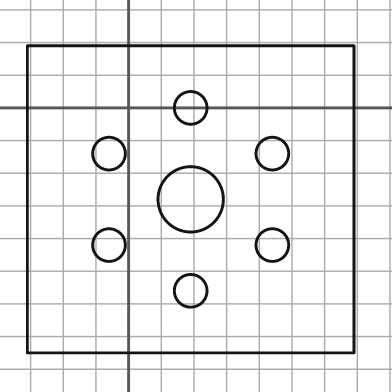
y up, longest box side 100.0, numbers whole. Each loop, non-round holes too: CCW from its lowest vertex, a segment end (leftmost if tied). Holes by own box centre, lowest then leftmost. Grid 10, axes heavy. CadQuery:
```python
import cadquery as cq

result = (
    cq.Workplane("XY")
    .moveTo(-31.0, -75.0)
    .lineTo(69.0, -75.0)
    .lineTo(69.0, 19.0)
    .lineTo(-31.0, 19.0)
    .close()
    .moveTo(19.0, -56.0)
    .circle(5.0)
    .moveTo(-6.0, -42.0)
    .circle(5.0)
    .moveTo(44.0, -42.0)
    .circle(5.0)
    .moveTo(19.0, -28.0)
    .circle(10.0)
    .moveTo(-6.0, -14.0)
    .circle(5.0)
    .moveTo(44.0, -14.0)
    .circle(5.0)
    .moveTo(19.0, 0.0)
    .circle(5.0)
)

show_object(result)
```